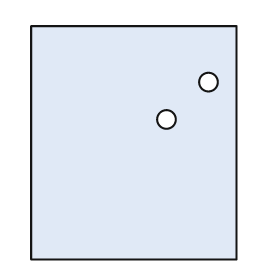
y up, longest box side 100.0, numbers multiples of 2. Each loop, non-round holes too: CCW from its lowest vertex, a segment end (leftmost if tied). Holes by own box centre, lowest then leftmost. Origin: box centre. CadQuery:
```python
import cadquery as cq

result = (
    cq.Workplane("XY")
    .moveTo(-44.0, -50.0)
    .lineTo(44.0, -50.0)
    .lineTo(44.0, 50.0)
    .lineTo(-44.0, 50.0)
    .close()
    .moveTo(14.0, 10.0)
    .circle(4.0)
    .moveTo(32.0, 26.0)
    .circle(4.0)
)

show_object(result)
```